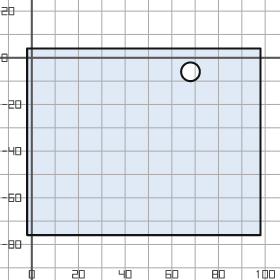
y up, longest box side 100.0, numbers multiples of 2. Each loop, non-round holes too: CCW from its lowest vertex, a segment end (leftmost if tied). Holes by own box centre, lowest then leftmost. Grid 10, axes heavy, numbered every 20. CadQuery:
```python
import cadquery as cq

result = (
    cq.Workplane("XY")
    .moveTo(-2.0, -76.0)
    .lineTo(98.0, -76.0)
    .lineTo(98.0, 4.0)
    .lineTo(-2.0, 4.0)
    .close()
    .moveTo(68.0, -6.0)
    .circle(4.0)
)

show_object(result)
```